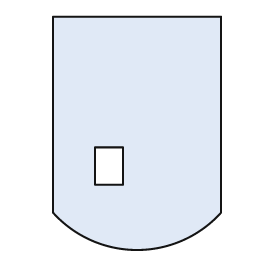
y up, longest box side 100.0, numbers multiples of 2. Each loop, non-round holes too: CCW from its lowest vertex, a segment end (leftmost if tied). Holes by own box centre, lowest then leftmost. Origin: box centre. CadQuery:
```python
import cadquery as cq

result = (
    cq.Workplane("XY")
    .moveTo(-36.0, -34.0)
    .threePointArc((0.0, -50.0), (36.0, -34.0))
    .lineTo(36.0, 50.0)
    .lineTo(-36.0, 50.0)
    .close()
    .moveTo(-18.0, -22.0)
    .lineTo(-6.0, -22.0)
    .lineTo(-6.0, -6.0)
    .lineTo(-18.0, -6.0)
    .close()
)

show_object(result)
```